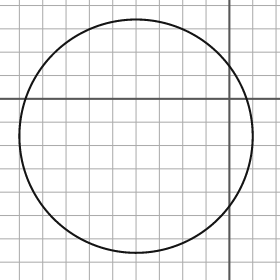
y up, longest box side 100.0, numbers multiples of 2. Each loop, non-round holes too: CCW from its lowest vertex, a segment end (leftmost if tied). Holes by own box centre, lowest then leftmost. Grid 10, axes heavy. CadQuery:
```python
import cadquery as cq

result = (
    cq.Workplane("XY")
    .moveTo(-40.0, -16.0)
    .circle(50.0)
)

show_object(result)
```